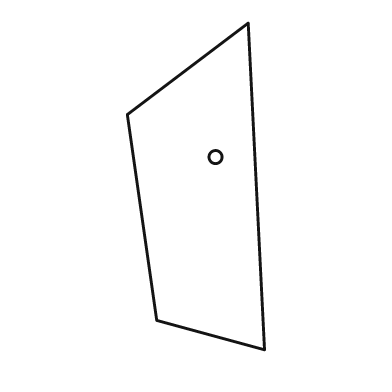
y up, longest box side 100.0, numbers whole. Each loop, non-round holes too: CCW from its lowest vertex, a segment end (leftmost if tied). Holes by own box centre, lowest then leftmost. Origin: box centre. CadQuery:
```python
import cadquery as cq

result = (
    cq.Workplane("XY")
    .moveTo(21.0, -50.0)
    .lineTo(16.0, 50.0)
    .lineTo(-21.0, 22.0)
    .lineTo(-12.0, -41.0)
    .close()
    .moveTo(6.0, 9.0)
    .circle(2.0)
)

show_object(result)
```